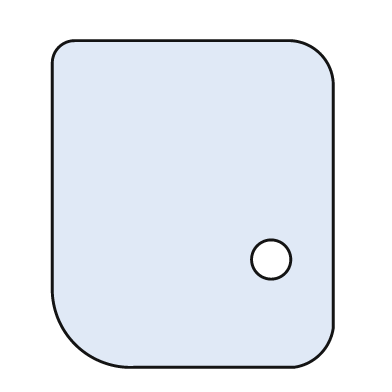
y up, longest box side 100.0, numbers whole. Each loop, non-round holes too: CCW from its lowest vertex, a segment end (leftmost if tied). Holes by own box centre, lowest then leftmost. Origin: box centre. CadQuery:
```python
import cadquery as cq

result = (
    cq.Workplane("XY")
    .moveTo(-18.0, -50.0)
    .lineTo(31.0, -50.0)
    .threePointArc((39.0, -46.0), (43.0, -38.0))
    .lineTo(43.0, 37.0)
    .threePointArc((39.0, 46.0), (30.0, 50.0))
    .lineTo(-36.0, 50.0)
    .threePointArc((-41.0, 48.0), (-43.0, 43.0))
    .lineTo(-43.0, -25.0)
    .threePointArc((-36.0, -43.0), (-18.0, -50.0))
    .close()
    .moveTo(24.0, -17.0)
    .circle(6.0)
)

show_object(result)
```